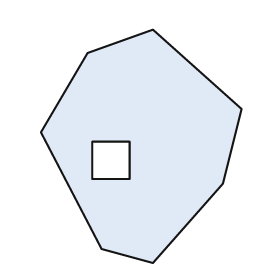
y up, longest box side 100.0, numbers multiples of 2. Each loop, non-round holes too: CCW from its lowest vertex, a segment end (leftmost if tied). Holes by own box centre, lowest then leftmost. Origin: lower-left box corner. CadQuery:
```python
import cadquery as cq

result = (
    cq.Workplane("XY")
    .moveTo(48.0, 0.0)
    .lineTo(78.0, 34.0)
    .lineTo(86.0, 66.0)
    .lineTo(48.0, 100.0)
    .lineTo(20.0, 90.0)
    .lineTo(0.0, 56.0)
    .lineTo(26.0, 6.0)
    .close()
    .moveTo(22.0, 36.0)
    .lineTo(38.0, 36.0)
    .lineTo(38.0, 52.0)
    .lineTo(22.0, 52.0)
    .close()
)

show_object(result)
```